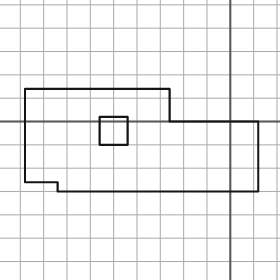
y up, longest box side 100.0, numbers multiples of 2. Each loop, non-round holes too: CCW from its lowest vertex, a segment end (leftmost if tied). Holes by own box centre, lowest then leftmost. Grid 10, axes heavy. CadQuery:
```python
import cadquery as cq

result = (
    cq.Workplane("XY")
    .moveTo(-74.0, -30.0)
    .lineTo(12.0, -30.0)
    .lineTo(12.0, 0.0)
    .lineTo(-26.0, 0.0)
    .lineTo(-26.0, 14.0)
    .lineTo(-88.0, 14.0)
    .lineTo(-88.0, -26.0)
    .lineTo(-74.0, -26.0)
    .close()
    .moveTo(-56.0, -10.0)
    .lineTo(-44.0, -10.0)
    .lineTo(-44.0, 2.0)
    .lineTo(-56.0, 2.0)
    .close()
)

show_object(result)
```